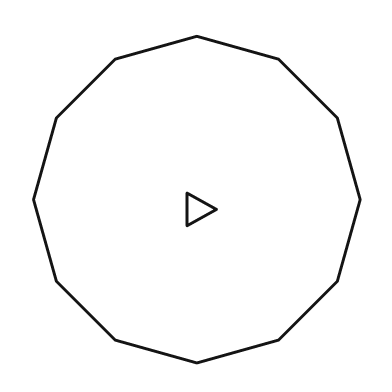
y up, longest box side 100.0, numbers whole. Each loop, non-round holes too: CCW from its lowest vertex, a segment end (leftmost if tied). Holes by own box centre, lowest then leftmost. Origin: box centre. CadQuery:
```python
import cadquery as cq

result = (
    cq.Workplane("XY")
    .moveTo(0.0, -50.0)
    .lineTo(25.0, -43.0)
    .lineTo(43.0, -25.0)
    .lineTo(50.0, 0.0)
    .lineTo(43.0, 25.0)
    .lineTo(25.0, 43.0)
    .lineTo(0.0, 50.0)
    .lineTo(-25.0, 43.0)
    .lineTo(-43.0, 25.0)
    .lineTo(-50.0, 0.0)
    .lineTo(-43.0, -25.0)
    .lineTo(-25.0, -43.0)
    .close()
    .moveTo(-3.0, -8.0)
    .lineTo(6.0, -3.0)
    .lineTo(-3.0, 2.0)
    .close()
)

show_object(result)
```